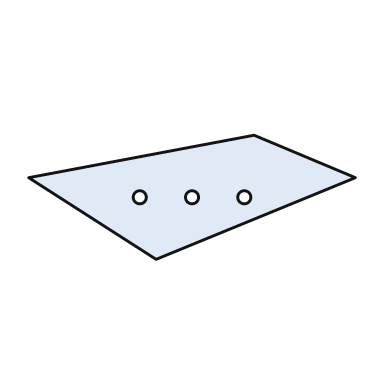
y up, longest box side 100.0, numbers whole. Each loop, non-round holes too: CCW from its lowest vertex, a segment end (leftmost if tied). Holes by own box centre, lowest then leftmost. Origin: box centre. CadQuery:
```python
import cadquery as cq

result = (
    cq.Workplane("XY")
    .moveTo(-11.0, -19.0)
    .lineTo(50.0, 6.0)
    .lineTo(19.0, 19.0)
    .lineTo(-50.0, 6.0)
    .close()
    .moveTo(-16.0, 0.0)
    .circle(2.0)
    .moveTo(0.0, 0.0)
    .circle(2.0)
    .moveTo(16.0, 0.0)
    .circle(2.0)
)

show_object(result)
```